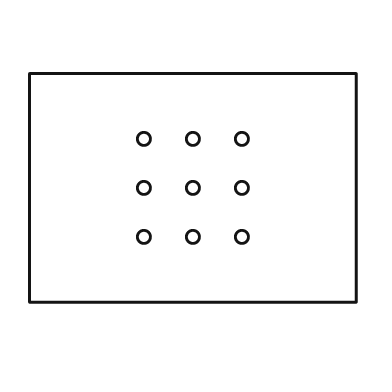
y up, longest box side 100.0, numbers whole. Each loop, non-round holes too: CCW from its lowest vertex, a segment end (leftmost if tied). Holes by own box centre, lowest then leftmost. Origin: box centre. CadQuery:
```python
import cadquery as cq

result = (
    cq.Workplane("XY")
    .moveTo(-50.0, -35.0)
    .lineTo(50.0, -35.0)
    .lineTo(50.0, 35.0)
    .lineTo(-50.0, 35.0)
    .close()
    .moveTo(-15.0, -15.0)
    .circle(2.0)
    .moveTo(0.0, -15.0)
    .circle(2.0)
    .moveTo(15.0, -15.0)
    .circle(2.0)
    .moveTo(-15.0, 0.0)
    .circle(2.0)
    .moveTo(0.0, 0.0)
    .circle(2.0)
    .moveTo(15.0, 0.0)
    .circle(2.0)
    .moveTo(-15.0, 15.0)
    .circle(2.0)
    .moveTo(0.0, 15.0)
    .circle(2.0)
    .moveTo(15.0, 15.0)
    .circle(2.0)
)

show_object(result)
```